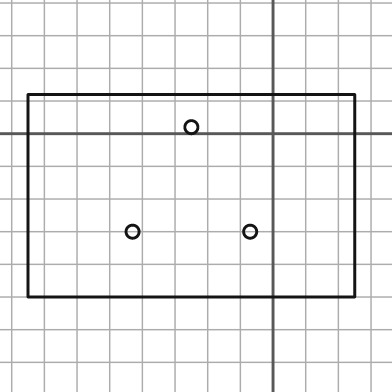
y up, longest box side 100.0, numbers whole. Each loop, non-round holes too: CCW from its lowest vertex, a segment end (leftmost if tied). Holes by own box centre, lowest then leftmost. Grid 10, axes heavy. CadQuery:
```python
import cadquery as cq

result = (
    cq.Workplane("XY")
    .moveTo(-75.0, -50.0)
    .lineTo(25.0, -50.0)
    .lineTo(25.0, 12.0)
    .lineTo(-75.0, 12.0)
    .close()
    .moveTo(-43.0, -30.0)
    .circle(2.0)
    .moveTo(-7.0, -30.0)
    .circle(2.0)
    .moveTo(-25.0, 2.0)
    .circle(2.0)
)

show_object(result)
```